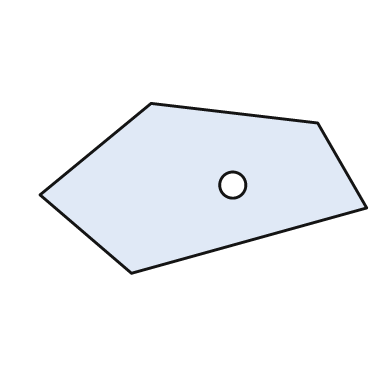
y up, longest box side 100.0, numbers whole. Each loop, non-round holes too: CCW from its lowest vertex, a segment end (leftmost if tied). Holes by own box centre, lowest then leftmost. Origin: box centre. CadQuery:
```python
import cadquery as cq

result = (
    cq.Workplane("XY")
    .moveTo(-22.0, -26.0)
    .lineTo(50.0, -6.0)
    .lineTo(35.0, 20.0)
    .lineTo(-16.0, 26.0)
    .lineTo(-50.0, -2.0)
    .close()
    .moveTo(9.0, 1.0)
    .circle(4.0)
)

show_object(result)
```